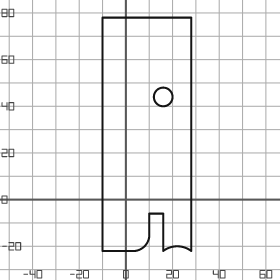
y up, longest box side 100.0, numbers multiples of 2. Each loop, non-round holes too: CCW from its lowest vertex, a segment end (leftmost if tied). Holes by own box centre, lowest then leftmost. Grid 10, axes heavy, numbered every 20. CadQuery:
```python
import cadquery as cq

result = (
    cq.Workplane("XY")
    .moveTo(-10.0, -22.0)
    .lineTo(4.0, -22.0)
    .threePointArc((8.0, -20.0), (10.0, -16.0))
    .lineTo(10.0, -6.0)
    .lineTo(16.0, -6.0)
    .lineTo(16.0, -22.0)
    .threePointArc((22.0, -20.0), (28.0, -22.0))
    .lineTo(28.0, 78.0)
    .lineTo(-10.0, 78.0)
    .close()
    .moveTo(16.0, 44.0)
    .circle(4.0)
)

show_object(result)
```